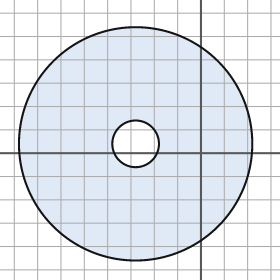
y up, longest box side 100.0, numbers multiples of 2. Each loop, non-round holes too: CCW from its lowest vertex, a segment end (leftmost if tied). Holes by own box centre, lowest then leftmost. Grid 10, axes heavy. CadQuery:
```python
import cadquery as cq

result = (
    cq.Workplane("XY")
    .moveTo(-28.0, 4.0)
    .circle(50.0)
    .moveTo(-28.0, 4.0)
    .circle(10.0)
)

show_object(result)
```